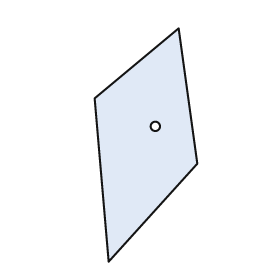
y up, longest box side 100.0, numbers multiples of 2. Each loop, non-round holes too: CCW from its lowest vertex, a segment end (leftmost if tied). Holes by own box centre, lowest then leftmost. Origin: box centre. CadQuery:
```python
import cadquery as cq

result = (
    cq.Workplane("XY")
    .moveTo(-16.0, -50.0)
    .lineTo(22.0, -8.0)
    .lineTo(14.0, 50.0)
    .lineTo(-22.0, 20.0)
    .close()
    .moveTo(4.0, 8.0)
    .circle(2.0)
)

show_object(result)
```